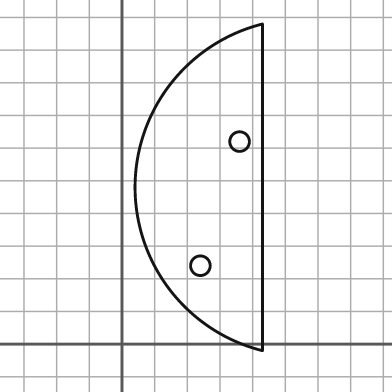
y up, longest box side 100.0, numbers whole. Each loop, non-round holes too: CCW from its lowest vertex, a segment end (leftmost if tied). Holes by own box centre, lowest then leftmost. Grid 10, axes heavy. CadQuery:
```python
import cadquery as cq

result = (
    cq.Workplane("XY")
    .moveTo(43.0, -2.0)
    .lineTo(43.0, 98.0)
    .threePointArc((4.0, 48.0), (43.0, -2.0))
    .close()
    .moveTo(24.0, 24.0)
    .circle(3.0)
    .moveTo(36.0, 62.0)
    .circle(3.0)
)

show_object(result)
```